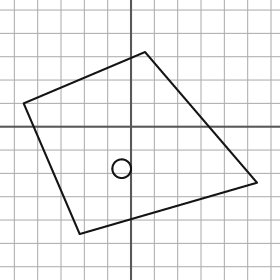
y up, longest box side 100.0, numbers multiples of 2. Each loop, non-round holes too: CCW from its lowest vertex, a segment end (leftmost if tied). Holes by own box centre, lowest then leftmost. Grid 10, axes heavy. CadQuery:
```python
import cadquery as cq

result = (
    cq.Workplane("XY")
    .moveTo(-22.0, -46.0)
    .lineTo(54.0, -24.0)
    .lineTo(6.0, 32.0)
    .lineTo(-46.0, 10.0)
    .close()
    .moveTo(-4.0, -18.0)
    .circle(4.0)
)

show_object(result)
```